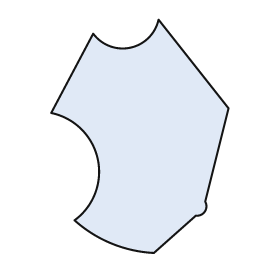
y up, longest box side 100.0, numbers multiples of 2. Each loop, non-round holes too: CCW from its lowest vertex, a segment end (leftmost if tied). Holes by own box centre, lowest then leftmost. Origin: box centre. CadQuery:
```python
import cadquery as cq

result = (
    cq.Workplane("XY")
    .moveTo(6.0, -50.0)
    .lineTo(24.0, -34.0)
    .threePointArc((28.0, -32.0), (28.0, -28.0))
    .lineTo(38.0, 12.0)
    .lineTo(8.0, 50.0)
    .threePointArc((-4.0, 38.0), (-20.0, 44.0))
    .lineTo(-38.0, 10.0)
    .threePointArc((-18.0, -10.0), (-28.0, -36.0))
    .threePointArc((-12.0, -46.0), (6.0, -50.0))
    .close()
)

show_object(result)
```